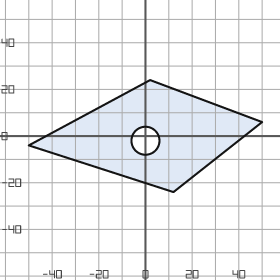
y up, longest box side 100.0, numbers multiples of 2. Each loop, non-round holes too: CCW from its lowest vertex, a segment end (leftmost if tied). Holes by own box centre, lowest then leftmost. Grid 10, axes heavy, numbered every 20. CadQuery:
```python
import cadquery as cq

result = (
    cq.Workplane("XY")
    .moveTo(12.0, -24.0)
    .lineTo(50.0, 6.0)
    .lineTo(2.0, 24.0)
    .lineTo(-50.0, -4.0)
    .close()
    .moveTo(0.0, -2.0)
    .circle(6.0)
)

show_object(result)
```